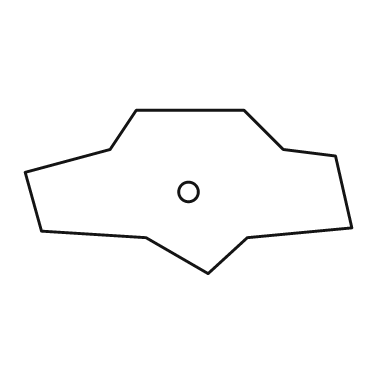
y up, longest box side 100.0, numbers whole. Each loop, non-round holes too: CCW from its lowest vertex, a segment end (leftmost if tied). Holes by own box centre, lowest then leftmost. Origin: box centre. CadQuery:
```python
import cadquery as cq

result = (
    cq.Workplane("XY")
    .moveTo(6.0, -25.0)
    .lineTo(18.0, -14.0)
    .lineTo(50.0, -11.0)
    .lineTo(45.0, 11.0)
    .lineTo(29.0, 13.0)
    .lineTo(17.0, 25.0)
    .lineTo(-16.0, 25.0)
    .lineTo(-24.0, 13.0)
    .lineTo(-50.0, 6.0)
    .lineTo(-45.0, -12.0)
    .lineTo(-13.0, -14.0)
    .close()
    .moveTo(0.0, 0.0)
    .circle(3.0)
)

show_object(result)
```